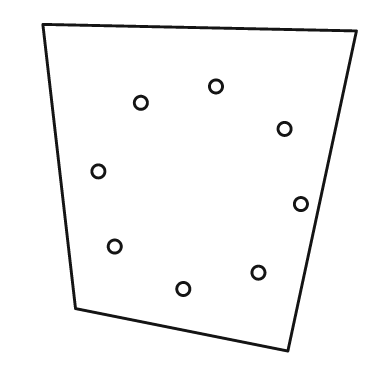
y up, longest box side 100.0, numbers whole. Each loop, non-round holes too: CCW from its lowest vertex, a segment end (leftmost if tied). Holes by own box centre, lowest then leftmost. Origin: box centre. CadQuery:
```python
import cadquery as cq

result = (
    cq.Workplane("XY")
    .moveTo(27.0, -50.0)
    .lineTo(48.0, 48.0)
    .lineTo(-48.0, 50.0)
    .lineTo(-38.0, -37.0)
    .close()
    .moveTo(-5.0, -31.0)
    .circle(2.0)
    .moveTo(18.0, -26.0)
    .circle(2.0)
    .moveTo(-26.0, -18.0)
    .circle(2.0)
    .moveTo(31.0, -5.0)
    .circle(2.0)
    .moveTo(-31.0, 5.0)
    .circle(2.0)
    .moveTo(26.0, 18.0)
    .circle(2.0)
    .moveTo(-18.0, 26.0)
    .circle(2.0)
    .moveTo(5.0, 31.0)
    .circle(2.0)
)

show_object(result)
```